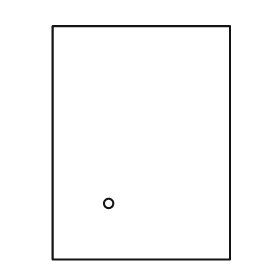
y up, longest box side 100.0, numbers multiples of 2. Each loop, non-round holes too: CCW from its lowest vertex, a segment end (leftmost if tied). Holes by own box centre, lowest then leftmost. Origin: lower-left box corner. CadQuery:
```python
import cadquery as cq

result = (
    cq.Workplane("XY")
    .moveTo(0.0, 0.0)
    .lineTo(76.0, 0.0)
    .lineTo(76.0, 100.0)
    .lineTo(0.0, 100.0)
    .close()
    .moveTo(24.0, 24.0)
    .circle(2.0)
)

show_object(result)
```